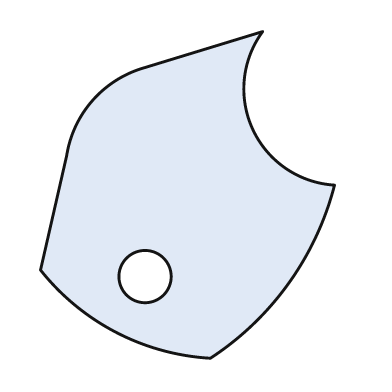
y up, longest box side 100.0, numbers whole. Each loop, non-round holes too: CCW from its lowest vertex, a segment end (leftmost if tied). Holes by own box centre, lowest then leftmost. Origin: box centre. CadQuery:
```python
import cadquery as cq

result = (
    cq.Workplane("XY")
    .moveTo(7.0, -50.0)
    .threePointArc((31.0, -27.0), (45.0, 3.0))
    .threePointArc((20.0, 20.0), (23.0, 50.0))
    .lineTo(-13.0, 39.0)
    .threePointArc((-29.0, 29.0), (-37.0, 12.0))
    .lineTo(-45.0, -23.0)
    .threePointArc((-22.0, -42.0), (7.0, -50.0))
    .close()
    .moveTo(-13.0, -25.0)
    .circle(8.0)
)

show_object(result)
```